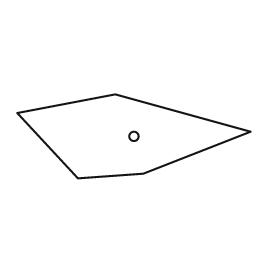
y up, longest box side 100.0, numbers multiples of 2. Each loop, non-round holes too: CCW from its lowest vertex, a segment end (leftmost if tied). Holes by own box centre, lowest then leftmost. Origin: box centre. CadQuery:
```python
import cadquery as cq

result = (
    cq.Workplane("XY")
    .moveTo(-24.0, -18.0)
    .lineTo(4.0, -16.0)
    .lineTo(50.0, 2.0)
    .lineTo(-8.0, 18.0)
    .lineTo(-50.0, 10.0)
    .close()
    .moveTo(0.0, 0.0)
    .circle(2.0)
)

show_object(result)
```